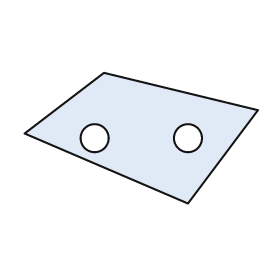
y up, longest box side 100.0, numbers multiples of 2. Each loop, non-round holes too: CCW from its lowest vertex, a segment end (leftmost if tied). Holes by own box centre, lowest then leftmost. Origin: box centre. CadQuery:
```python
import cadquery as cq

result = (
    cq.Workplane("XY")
    .moveTo(20.0, -28.0)
    .lineTo(50.0, 12.0)
    .lineTo(-16.0, 28.0)
    .lineTo(-50.0, 2.0)
    .close()
    .moveTo(-20.0, 0.0)
    .circle(6.0)
    .moveTo(20.0, 0.0)
    .circle(6.0)
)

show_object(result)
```